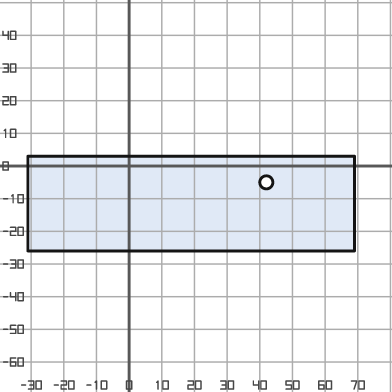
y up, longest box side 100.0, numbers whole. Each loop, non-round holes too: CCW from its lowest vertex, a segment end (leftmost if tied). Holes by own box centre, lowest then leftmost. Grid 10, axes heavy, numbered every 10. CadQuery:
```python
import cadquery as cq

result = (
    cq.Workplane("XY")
    .moveTo(-31.0, -26.0)
    .lineTo(69.0, -26.0)
    .lineTo(69.0, 3.0)
    .lineTo(-31.0, 3.0)
    .close()
    .moveTo(42.0, -5.0)
    .circle(2.0)
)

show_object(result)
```